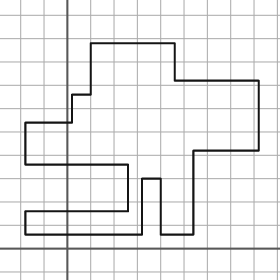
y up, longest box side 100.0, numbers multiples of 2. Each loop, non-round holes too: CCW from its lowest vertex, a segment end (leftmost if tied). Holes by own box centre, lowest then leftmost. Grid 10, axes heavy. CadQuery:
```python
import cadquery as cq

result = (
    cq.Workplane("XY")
    .moveTo(-18.0, 6.0)
    .lineTo(32.0, 6.0)
    .lineTo(32.0, 30.0)
    .lineTo(40.0, 30.0)
    .lineTo(40.0, 6.0)
    .lineTo(54.0, 6.0)
    .lineTo(54.0, 42.0)
    .lineTo(82.0, 42.0)
    .lineTo(82.0, 72.0)
    .lineTo(46.0, 72.0)
    .lineTo(46.0, 88.0)
    .lineTo(10.0, 88.0)
    .lineTo(10.0, 66.0)
    .lineTo(2.0, 66.0)
    .lineTo(2.0, 54.0)
    .lineTo(-18.0, 54.0)
    .lineTo(-18.0, 36.0)
    .lineTo(26.0, 36.0)
    .lineTo(26.0, 16.0)
    .lineTo(-18.0, 16.0)
    .close()
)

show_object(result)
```